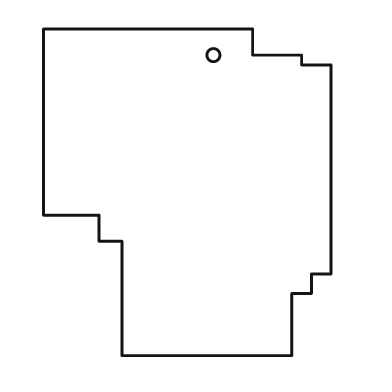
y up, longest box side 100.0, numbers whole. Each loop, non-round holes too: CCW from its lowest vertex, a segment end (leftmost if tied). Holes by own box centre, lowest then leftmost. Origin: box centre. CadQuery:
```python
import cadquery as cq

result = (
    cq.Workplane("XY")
    .moveTo(-20.0, -50.0)
    .lineTo(32.0, -50.0)
    .lineTo(32.0, -31.0)
    .lineTo(38.0, -31.0)
    .lineTo(38.0, -25.0)
    .lineTo(44.0, -25.0)
    .lineTo(44.0, 39.0)
    .lineTo(35.0, 39.0)
    .lineTo(35.0, 42.0)
    .lineTo(20.0, 42.0)
    .lineTo(20.0, 50.0)
    .lineTo(-44.0, 50.0)
    .lineTo(-44.0, -7.0)
    .lineTo(-27.0, -7.0)
    .lineTo(-27.0, -15.0)
    .lineTo(-20.0, -15.0)
    .close()
    .moveTo(8.0, 42.0)
    .circle(2.0)
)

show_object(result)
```